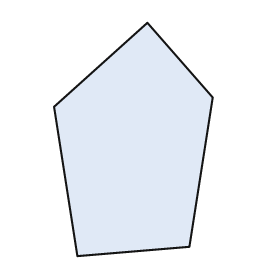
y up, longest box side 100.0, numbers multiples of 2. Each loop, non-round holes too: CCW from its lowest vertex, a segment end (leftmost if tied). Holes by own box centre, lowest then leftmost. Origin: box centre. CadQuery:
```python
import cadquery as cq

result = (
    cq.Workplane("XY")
    .moveTo(-24.0, -50.0)
    .lineTo(24.0, -46.0)
    .lineTo(34.0, 18.0)
    .lineTo(6.0, 50.0)
    .lineTo(-34.0, 14.0)
    .close()
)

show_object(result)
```